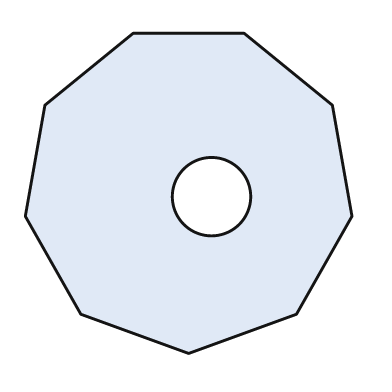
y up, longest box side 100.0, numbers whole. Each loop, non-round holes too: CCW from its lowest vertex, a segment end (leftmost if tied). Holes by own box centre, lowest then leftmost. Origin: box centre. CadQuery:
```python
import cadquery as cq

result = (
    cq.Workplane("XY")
    .moveTo(0.0, -49.0)
    .lineTo(33.0, -37.0)
    .lineTo(50.0, -7.0)
    .lineTo(44.0, 27.0)
    .lineTo(17.0, 49.0)
    .lineTo(-17.0, 49.0)
    .lineTo(-44.0, 27.0)
    .lineTo(-50.0, -7.0)
    .lineTo(-33.0, -37.0)
    .close()
    .moveTo(7.0, -1.0)
    .circle(12.0)
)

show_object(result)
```